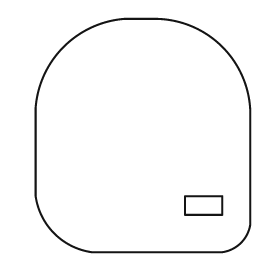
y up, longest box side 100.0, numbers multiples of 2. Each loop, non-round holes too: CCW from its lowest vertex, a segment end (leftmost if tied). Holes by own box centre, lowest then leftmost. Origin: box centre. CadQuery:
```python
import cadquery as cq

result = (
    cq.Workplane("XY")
    .moveTo(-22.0, -50.0)
    .lineTo(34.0, -50.0)
    .threePointArc((42.0, -46.0), (46.0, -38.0))
    .lineTo(46.0, 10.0)
    .threePointArc((34.0, 38.0), (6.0, 50.0))
    .lineTo(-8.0, 50.0)
    .threePointArc((-34.0, 38.0), (-46.0, 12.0))
    .lineTo(-46.0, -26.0)
    .threePointArc((-38.0, -42.0), (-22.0, -50.0))
    .close()
    .moveTo(18.0, -34.0)
    .lineTo(34.0, -34.0)
    .lineTo(34.0, -26.0)
    .lineTo(18.0, -26.0)
    .close()
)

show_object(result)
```